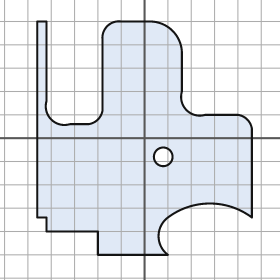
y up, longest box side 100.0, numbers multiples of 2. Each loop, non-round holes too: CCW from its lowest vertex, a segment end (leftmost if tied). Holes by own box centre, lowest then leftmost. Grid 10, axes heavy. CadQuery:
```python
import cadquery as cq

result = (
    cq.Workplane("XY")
    .moveTo(-20.0, -50.0)
    .lineTo(10.0, -50.0)
    .threePointArc((6.0, -42.0), (10.0, -34.0))
    .threePointArc((28.0, -28.0), (46.0, -34.0))
    .lineTo(46.0, 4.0)
    .threePointArc((44.0, 8.0), (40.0, 10.0))
    .lineTo(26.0, 10.0)
    .threePointArc((18.0, 12.0), (16.0, 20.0))
    .lineTo(16.0, 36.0)
    .threePointArc((12.0, 46.0), (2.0, 50.0))
    .lineTo(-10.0, 50.0)
    .threePointArc((-16.0, 48.0), (-18.0, 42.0))
    .lineTo(-18.0, 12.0)
    .threePointArc((-20.0, 8.0), (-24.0, 6.0))
    .lineTo(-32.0, 6.0)
    .threePointArc((-40.0, 8.0), (-42.0, 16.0))
    .lineTo(-42.0, 50.0)
    .lineTo(-46.0, 50.0)
    .lineTo(-46.0, -34.0)
    .lineTo(-42.0, -34.0)
    .lineTo(-42.0, -40.0)
    .lineTo(-20.0, -40.0)
    .close()
    .moveTo(8.0, -8.0)
    .circle(4.0)
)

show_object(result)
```